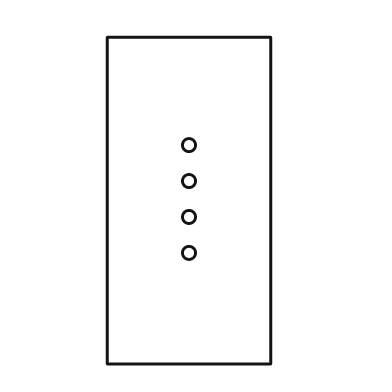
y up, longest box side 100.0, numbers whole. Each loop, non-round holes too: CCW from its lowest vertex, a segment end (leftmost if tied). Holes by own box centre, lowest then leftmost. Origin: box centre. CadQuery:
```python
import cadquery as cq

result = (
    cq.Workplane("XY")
    .moveTo(-25.0, -50.0)
    .lineTo(25.0, -50.0)
    .lineTo(25.0, 50.0)
    .lineTo(-25.0, 50.0)
    .close()
    .moveTo(0.0, -16.0)
    .circle(2.0)
    .moveTo(0.0, -5.0)
    .circle(2.0)
    .moveTo(0.0, 6.0)
    .circle(2.0)
    .moveTo(0.0, 17.0)
    .circle(2.0)
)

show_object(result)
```